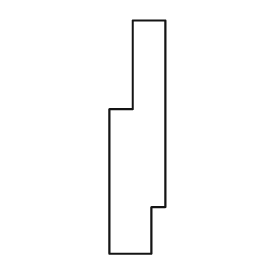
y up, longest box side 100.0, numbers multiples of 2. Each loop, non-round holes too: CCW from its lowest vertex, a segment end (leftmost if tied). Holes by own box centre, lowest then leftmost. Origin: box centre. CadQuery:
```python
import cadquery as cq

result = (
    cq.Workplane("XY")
    .moveTo(-12.0, -50.0)
    .lineTo(6.0, -50.0)
    .lineTo(6.0, -30.0)
    .lineTo(12.0, -30.0)
    .lineTo(12.0, 50.0)
    .lineTo(-2.0, 50.0)
    .lineTo(-2.0, 12.0)
    .lineTo(-12.0, 12.0)
    .close()
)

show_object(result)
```